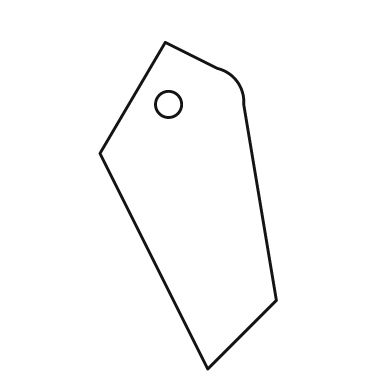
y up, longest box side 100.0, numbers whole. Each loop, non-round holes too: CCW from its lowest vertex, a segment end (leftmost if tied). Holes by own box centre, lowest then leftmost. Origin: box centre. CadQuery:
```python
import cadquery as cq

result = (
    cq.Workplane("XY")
    .moveTo(6.0, -50.0)
    .lineTo(27.0, -29.0)
    .lineTo(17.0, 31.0)
    .threePointArc((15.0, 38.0), (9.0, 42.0))
    .lineTo(-7.0, 50.0)
    .lineTo(-27.0, 16.0)
    .close()
    .moveTo(-6.0, 31.0)
    .circle(4.0)
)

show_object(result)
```